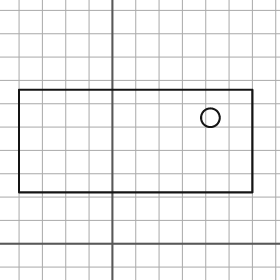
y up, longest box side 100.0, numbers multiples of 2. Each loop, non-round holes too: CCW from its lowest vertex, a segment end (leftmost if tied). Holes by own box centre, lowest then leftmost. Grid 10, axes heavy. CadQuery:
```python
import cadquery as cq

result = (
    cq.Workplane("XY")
    .moveTo(-40.0, 22.0)
    .lineTo(60.0, 22.0)
    .lineTo(60.0, 66.0)
    .lineTo(-40.0, 66.0)
    .close()
    .moveTo(42.0, 54.0)
    .circle(4.0)
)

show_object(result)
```